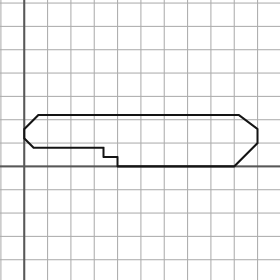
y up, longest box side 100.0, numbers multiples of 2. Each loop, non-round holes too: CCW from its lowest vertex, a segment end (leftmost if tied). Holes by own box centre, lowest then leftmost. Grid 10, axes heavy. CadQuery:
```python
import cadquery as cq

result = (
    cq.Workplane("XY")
    .moveTo(40.0, 0.0)
    .lineTo(90.0, 0.0)
    .lineTo(100.0, 10.0)
    .lineTo(100.0, 16.0)
    .lineTo(92.0, 22.0)
    .lineTo(6.0, 22.0)
    .lineTo(0.0, 16.0)
    .lineTo(0.0, 12.0)
    .lineTo(4.0, 8.0)
    .lineTo(34.0, 8.0)
    .lineTo(34.0, 4.0)
    .lineTo(40.0, 4.0)
    .close()
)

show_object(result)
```